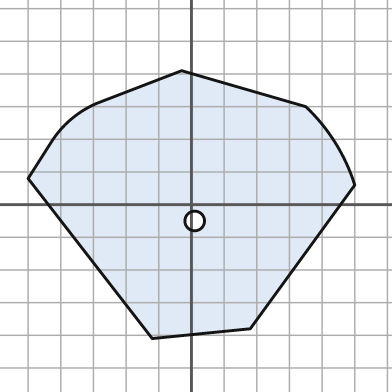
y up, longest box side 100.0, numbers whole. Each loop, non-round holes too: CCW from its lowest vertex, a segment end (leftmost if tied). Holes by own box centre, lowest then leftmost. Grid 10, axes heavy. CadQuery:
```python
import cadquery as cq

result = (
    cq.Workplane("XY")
    .moveTo(-12.0, -41.0)
    .lineTo(18.0, -38.0)
    .lineTo(50.0, 6.0)
    .threePointArc((44.0, 19.0), (35.0, 30.0))
    .lineTo(-3.0, 41.0)
    .lineTo(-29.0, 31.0)
    .threePointArc((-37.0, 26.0), (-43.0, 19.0))
    .lineTo(-50.0, 8.0)
    .close()
    .moveTo(1.0, -5.0)
    .circle(3.0)
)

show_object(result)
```